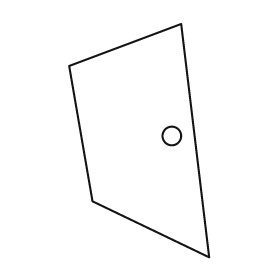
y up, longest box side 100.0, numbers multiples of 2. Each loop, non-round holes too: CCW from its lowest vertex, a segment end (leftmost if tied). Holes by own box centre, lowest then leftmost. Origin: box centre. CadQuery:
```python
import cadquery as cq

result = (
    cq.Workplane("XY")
    .moveTo(30.0, -50.0)
    .lineTo(18.0, 50.0)
    .lineTo(-30.0, 32.0)
    .lineTo(-20.0, -26.0)
    .close()
    .moveTo(14.0, 2.0)
    .circle(4.0)
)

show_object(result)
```